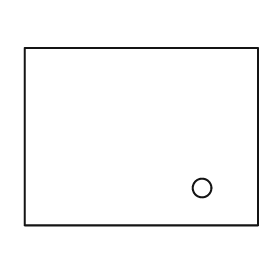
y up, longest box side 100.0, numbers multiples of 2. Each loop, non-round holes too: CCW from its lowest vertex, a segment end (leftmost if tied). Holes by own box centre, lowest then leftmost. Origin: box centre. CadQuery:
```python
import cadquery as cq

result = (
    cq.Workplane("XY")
    .moveTo(-50.0, -38.0)
    .lineTo(50.0, -38.0)
    .lineTo(50.0, 38.0)
    .lineTo(-50.0, 38.0)
    .close()
    .moveTo(26.0, -22.0)
    .circle(4.0)
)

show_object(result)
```